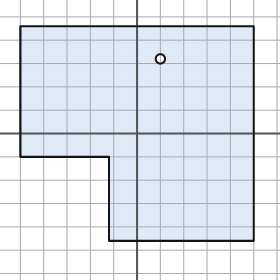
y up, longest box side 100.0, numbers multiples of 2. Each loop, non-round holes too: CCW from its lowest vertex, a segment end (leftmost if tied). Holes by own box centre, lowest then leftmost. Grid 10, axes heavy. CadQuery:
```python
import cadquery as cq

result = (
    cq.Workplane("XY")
    .moveTo(-12.0, -46.0)
    .lineTo(50.0, -46.0)
    .lineTo(50.0, 46.0)
    .lineTo(-50.0, 46.0)
    .lineTo(-50.0, -10.0)
    .lineTo(-12.0, -10.0)
    .close()
    .moveTo(10.0, 32.0)
    .circle(2.0)
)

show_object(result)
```